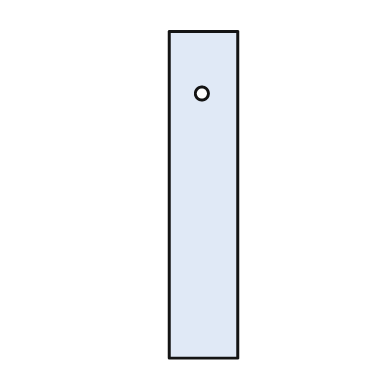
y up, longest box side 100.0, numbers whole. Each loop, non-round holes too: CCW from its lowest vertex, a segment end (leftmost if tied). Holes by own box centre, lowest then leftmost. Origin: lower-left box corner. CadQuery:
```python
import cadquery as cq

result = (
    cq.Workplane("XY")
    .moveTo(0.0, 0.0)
    .lineTo(21.0, 0.0)
    .lineTo(21.0, 100.0)
    .lineTo(0.0, 100.0)
    .close()
    .moveTo(10.0, 81.0)
    .circle(2.0)
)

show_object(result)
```